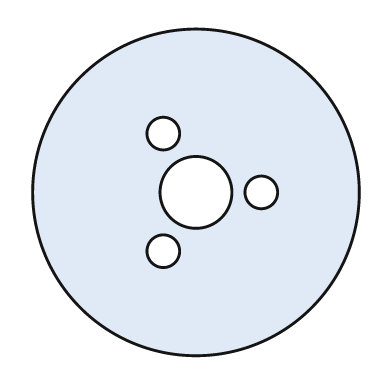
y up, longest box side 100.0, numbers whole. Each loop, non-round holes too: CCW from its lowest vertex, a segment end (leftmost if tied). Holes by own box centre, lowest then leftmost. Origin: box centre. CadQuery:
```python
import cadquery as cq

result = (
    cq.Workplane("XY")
    .moveTo(0.0, 0.0)
    .circle(50.0)
    .moveTo(-10.0, -18.0)
    .circle(5.0)
    .moveTo(0.0, 0.0)
    .circle(11.0)
    .moveTo(20.0, 0.0)
    .circle(5.0)
    .moveTo(-10.0, 18.0)
    .circle(5.0)
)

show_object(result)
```